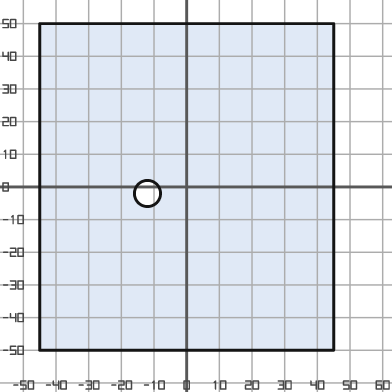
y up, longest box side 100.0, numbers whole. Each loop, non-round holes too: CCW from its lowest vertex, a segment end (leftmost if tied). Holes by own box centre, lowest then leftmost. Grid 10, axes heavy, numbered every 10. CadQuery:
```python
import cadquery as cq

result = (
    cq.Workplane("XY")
    .moveTo(-45.0, -50.0)
    .lineTo(45.0, -50.0)
    .lineTo(45.0, 50.0)
    .lineTo(-45.0, 50.0)
    .close()
    .moveTo(-12.0, -2.0)
    .circle(4.0)
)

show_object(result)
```